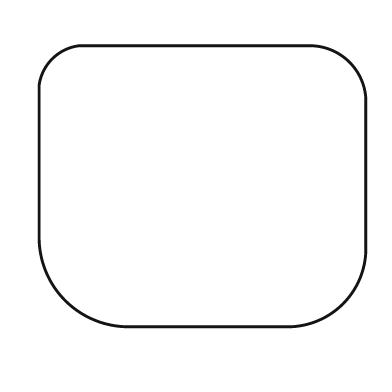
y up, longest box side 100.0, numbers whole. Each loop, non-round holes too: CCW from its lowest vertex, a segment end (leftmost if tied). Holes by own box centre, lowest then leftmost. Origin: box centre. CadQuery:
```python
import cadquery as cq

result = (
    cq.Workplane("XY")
    .moveTo(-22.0, -43.0)
    .lineTo(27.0, -43.0)
    .threePointArc((43.0, -36.0), (50.0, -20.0))
    .lineTo(50.0, 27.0)
    .threePointArc((45.0, 38.0), (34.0, 43.0))
    .lineTo(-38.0, 43.0)
    .threePointArc((-46.0, 39.0), (-50.0, 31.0))
    .lineTo(-50.0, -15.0)
    .threePointArc((-42.0, -35.0), (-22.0, -43.0))
    .close()
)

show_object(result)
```